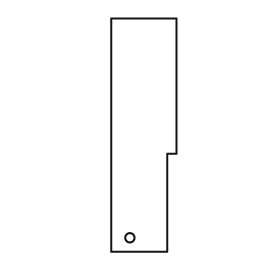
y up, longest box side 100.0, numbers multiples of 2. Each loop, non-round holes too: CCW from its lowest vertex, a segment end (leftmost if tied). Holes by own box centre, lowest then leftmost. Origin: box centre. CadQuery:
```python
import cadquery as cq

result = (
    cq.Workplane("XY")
    .moveTo(-14.0, -50.0)
    .lineTo(10.0, -50.0)
    .lineTo(10.0, -8.0)
    .lineTo(14.0, -8.0)
    .lineTo(14.0, 50.0)
    .lineTo(-14.0, 50.0)
    .close()
    .moveTo(-6.0, -44.0)
    .circle(2.0)
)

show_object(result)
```